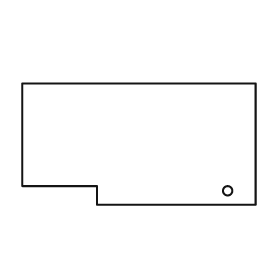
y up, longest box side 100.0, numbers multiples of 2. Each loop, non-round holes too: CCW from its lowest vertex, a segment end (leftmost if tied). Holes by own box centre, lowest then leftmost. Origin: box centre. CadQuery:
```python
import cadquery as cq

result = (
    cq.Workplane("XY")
    .moveTo(-18.0, -26.0)
    .lineTo(50.0, -26.0)
    .lineTo(50.0, 26.0)
    .lineTo(-50.0, 26.0)
    .lineTo(-50.0, -18.0)
    .lineTo(-18.0, -18.0)
    .close()
    .moveTo(38.0, -20.0)
    .circle(2.0)
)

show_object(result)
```